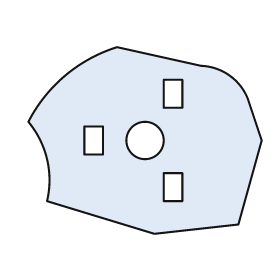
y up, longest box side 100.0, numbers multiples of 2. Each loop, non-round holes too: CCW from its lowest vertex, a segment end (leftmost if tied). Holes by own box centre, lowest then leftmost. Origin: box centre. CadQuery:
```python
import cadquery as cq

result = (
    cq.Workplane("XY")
    .moveTo(4.0, -40.0)
    .lineTo(40.0, -36.0)
    .lineTo(50.0, 0.0)
    .lineTo(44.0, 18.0)
    .threePointArc((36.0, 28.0), (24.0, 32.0))
    .lineTo(-12.0, 40.0)
    .threePointArc((-34.0, 28.0), (-50.0, 8.0))
    .threePointArc((-42.0, -8.0), (-42.0, -26.0))
    .close()
    .moveTo(8.0, -26.0)
    .lineTo(16.0, -26.0)
    .lineTo(16.0, -14.0)
    .lineTo(8.0, -14.0)
    .close()
    .moveTo(-26.0, -6.0)
    .lineTo(-18.0, -6.0)
    .lineTo(-18.0, 6.0)
    .lineTo(-26.0, 6.0)
    .close()
    .moveTo(0.0, 0.0)
    .circle(8.0)
    .moveTo(8.0, 14.0)
    .lineTo(16.0, 14.0)
    .lineTo(16.0, 26.0)
    .lineTo(8.0, 26.0)
    .close()
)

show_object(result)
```